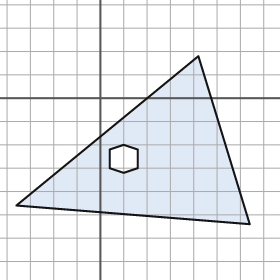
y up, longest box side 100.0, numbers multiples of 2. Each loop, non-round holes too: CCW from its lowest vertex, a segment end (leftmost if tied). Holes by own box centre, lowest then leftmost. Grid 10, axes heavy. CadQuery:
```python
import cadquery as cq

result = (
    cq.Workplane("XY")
    .moveTo(64.0, -54.0)
    .lineTo(42.0, 18.0)
    .lineTo(-36.0, -46.0)
    .close()
    .moveTo(10.0, -32.0)
    .lineTo(16.0, -30.0)
    .lineTo(16.0, -22.0)
    .lineTo(10.0, -20.0)
    .lineTo(4.0, -22.0)
    .lineTo(4.0, -30.0)
    .close()
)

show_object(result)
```